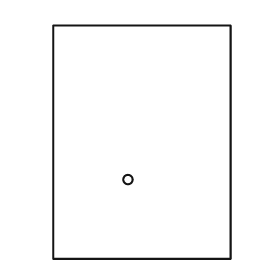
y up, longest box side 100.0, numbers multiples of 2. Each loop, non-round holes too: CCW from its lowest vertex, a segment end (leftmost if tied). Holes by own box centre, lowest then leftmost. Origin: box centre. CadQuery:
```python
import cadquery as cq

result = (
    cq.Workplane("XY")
    .moveTo(-38.0, -50.0)
    .lineTo(38.0, -50.0)
    .lineTo(38.0, 50.0)
    .lineTo(-38.0, 50.0)
    .close()
    .moveTo(-6.0, -16.0)
    .circle(2.0)
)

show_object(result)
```